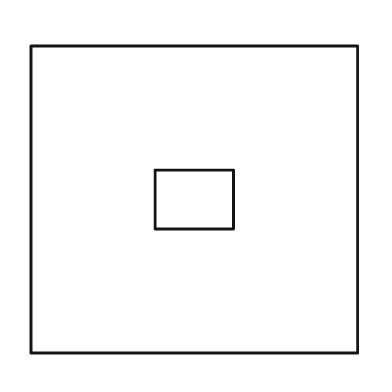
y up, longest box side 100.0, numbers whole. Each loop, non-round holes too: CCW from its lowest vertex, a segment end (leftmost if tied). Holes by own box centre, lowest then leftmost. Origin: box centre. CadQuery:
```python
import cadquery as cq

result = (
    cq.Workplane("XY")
    .moveTo(-50.0, -47.0)
    .lineTo(50.0, -47.0)
    .lineTo(50.0, 47.0)
    .lineTo(-50.0, 47.0)
    .close()
    .moveTo(-12.0, -9.0)
    .lineTo(12.0, -9.0)
    .lineTo(12.0, 9.0)
    .lineTo(-12.0, 9.0)
    .close()
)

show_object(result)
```